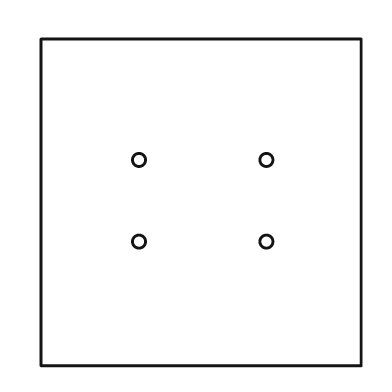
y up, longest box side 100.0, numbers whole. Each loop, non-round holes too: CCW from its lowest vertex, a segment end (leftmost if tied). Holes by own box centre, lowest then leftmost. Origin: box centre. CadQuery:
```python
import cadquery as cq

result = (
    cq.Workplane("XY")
    .moveTo(-49.0, -50.0)
    .lineTo(49.0, -50.0)
    .lineTo(49.0, 50.0)
    .lineTo(-49.0, 50.0)
    .close()
    .moveTo(-19.0, -12.0)
    .circle(2.0)
    .moveTo(20.0, -12.0)
    .circle(2.0)
    .moveTo(-19.0, 13.0)
    .circle(2.0)
    .moveTo(20.0, 13.0)
    .circle(2.0)
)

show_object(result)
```